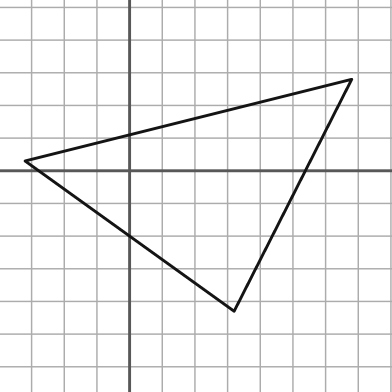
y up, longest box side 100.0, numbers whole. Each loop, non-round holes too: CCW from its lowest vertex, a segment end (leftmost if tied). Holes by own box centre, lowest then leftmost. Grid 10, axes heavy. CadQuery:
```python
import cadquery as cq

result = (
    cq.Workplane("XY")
    .moveTo(32.0, -43.0)
    .lineTo(68.0, 28.0)
    .lineTo(-32.0, 3.0)
    .close()
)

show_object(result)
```